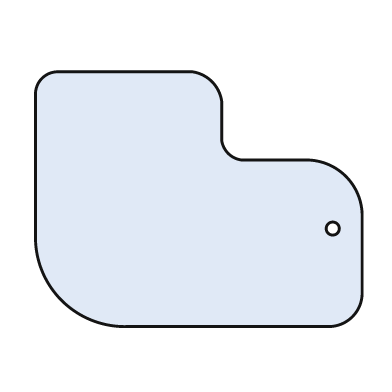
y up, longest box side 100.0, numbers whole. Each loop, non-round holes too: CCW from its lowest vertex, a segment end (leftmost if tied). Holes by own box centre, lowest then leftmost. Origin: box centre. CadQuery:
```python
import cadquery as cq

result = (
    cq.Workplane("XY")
    .moveTo(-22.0, -39.0)
    .lineTo(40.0, -39.0)
    .threePointArc((47.0, -36.0), (50.0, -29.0))
    .lineTo(50.0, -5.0)
    .threePointArc((45.0, 7.0), (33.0, 12.0))
    .lineTo(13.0, 12.0)
    .threePointArc((9.0, 14.0), (7.0, 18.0))
    .lineTo(7.0, 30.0)
    .threePointArc((4.0, 36.0), (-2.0, 39.0))
    .lineTo(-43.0, 39.0)
    .threePointArc((-48.0, 37.0), (-50.0, 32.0))
    .lineTo(-50.0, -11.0)
    .threePointArc((-42.0, -31.0), (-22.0, -39.0))
    .close()
    .moveTo(41.0, -9.0)
    .circle(2.0)
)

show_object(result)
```